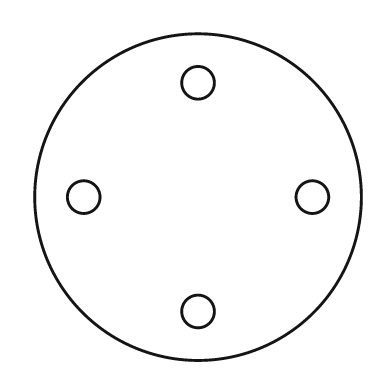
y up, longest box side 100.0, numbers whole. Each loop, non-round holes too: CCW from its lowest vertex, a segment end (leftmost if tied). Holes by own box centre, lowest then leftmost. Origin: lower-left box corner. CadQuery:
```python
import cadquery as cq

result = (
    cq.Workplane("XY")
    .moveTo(50.0, 50.0)
    .circle(50.0)
    .moveTo(50.0, 15.0)
    .circle(5.0)
    .moveTo(15.0, 50.0)
    .circle(5.0)
    .moveTo(85.0, 50.0)
    .circle(5.0)
    .moveTo(50.0, 85.0)
    .circle(5.0)
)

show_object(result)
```